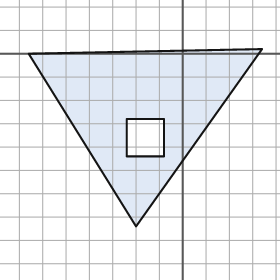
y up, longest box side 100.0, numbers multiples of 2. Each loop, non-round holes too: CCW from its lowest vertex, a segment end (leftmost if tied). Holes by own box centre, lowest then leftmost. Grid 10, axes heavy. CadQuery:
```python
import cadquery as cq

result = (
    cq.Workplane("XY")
    .moveTo(-20.0, -74.0)
    .lineTo(34.0, 2.0)
    .lineTo(-66.0, 0.0)
    .close()
    .moveTo(-24.0, -44.0)
    .lineTo(-8.0, -44.0)
    .lineTo(-8.0, -28.0)
    .lineTo(-24.0, -28.0)
    .close()
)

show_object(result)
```